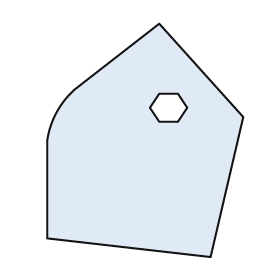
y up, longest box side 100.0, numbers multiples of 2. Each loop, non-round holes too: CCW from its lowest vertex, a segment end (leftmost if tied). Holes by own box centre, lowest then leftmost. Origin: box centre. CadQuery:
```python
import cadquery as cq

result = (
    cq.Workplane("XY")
    .moveTo(28.0, -50.0)
    .lineTo(42.0, 10.0)
    .lineTo(6.0, 50.0)
    .lineTo(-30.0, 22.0)
    .threePointArc((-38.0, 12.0), (-42.0, 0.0))
    .lineTo(-42.0, -42.0)
    .close()
    .moveTo(6.0, 8.0)
    .lineTo(14.0, 8.0)
    .lineTo(18.0, 14.0)
    .lineTo(14.0, 20.0)
    .lineTo(6.0, 20.0)
    .lineTo(2.0, 14.0)
    .close()
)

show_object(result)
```